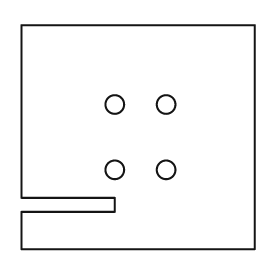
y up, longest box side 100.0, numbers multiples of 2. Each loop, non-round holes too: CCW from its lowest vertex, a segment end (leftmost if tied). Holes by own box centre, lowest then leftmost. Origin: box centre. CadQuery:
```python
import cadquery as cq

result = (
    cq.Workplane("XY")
    .moveTo(-50.0, -48.0)
    .lineTo(50.0, -48.0)
    .lineTo(50.0, 48.0)
    .lineTo(-50.0, 48.0)
    .lineTo(-50.0, -26.0)
    .lineTo(-10.0, -26.0)
    .lineTo(-10.0, -32.0)
    .lineTo(-50.0, -32.0)
    .close()
    .moveTo(-10.0, -14.0)
    .circle(4.0)
    .moveTo(12.0, -14.0)
    .circle(4.0)
    .moveTo(-10.0, 14.0)
    .circle(4.0)
    .moveTo(12.0, 14.0)
    .circle(4.0)
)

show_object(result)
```